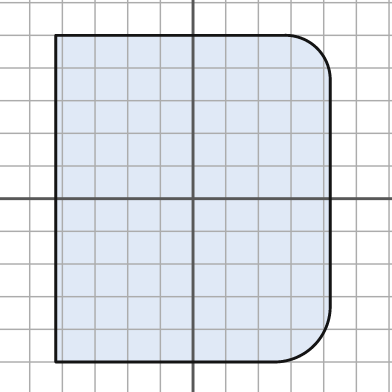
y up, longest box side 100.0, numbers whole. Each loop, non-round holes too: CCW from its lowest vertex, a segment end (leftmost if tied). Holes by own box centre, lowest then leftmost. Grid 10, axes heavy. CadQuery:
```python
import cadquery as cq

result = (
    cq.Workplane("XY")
    .moveTo(-42.0, -50.0)
    .lineTo(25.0, -50.0)
    .threePointArc((37.0, -45.0), (42.0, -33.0))
    .lineTo(42.0, 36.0)
    .threePointArc((38.0, 46.0), (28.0, 50.0))
    .lineTo(-42.0, 50.0)
    .close()
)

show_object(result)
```